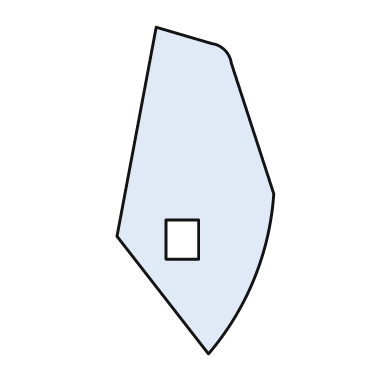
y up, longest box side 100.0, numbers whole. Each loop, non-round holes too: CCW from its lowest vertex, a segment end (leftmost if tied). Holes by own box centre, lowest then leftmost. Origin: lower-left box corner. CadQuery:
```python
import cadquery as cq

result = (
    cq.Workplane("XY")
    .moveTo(28.0, 0.0)
    .threePointArc((42.0, 23.0), (48.0, 49.0))
    .lineTo(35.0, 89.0)
    .threePointArc((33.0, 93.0), (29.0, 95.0))
    .lineTo(12.0, 100.0)
    .lineTo(0.0, 36.0)
    .close()
    .moveTo(15.0, 29.0)
    .lineTo(25.0, 29.0)
    .lineTo(25.0, 41.0)
    .lineTo(15.0, 41.0)
    .close()
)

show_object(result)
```